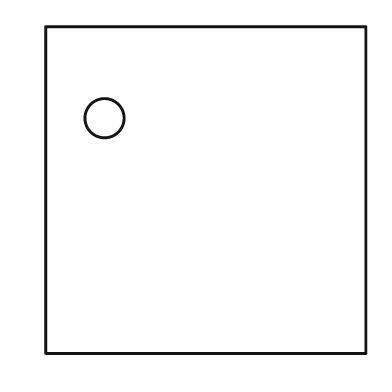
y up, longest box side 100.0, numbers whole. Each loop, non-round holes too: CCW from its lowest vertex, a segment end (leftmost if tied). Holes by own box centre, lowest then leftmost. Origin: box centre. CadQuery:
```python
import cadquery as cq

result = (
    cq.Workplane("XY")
    .moveTo(-49.0, -50.0)
    .lineTo(49.0, -50.0)
    .lineTo(49.0, 50.0)
    .lineTo(-49.0, 50.0)
    .close()
    .moveTo(-31.0, 22.0)
    .circle(6.0)
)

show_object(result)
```